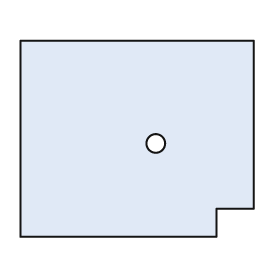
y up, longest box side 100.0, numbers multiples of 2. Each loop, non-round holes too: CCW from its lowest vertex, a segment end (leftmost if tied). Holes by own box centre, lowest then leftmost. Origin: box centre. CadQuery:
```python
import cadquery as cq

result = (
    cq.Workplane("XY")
    .moveTo(-50.0, -42.0)
    .lineTo(34.0, -42.0)
    .lineTo(34.0, -30.0)
    .lineTo(50.0, -30.0)
    .lineTo(50.0, 42.0)
    .lineTo(-50.0, 42.0)
    .close()
    .moveTo(8.0, -2.0)
    .circle(4.0)
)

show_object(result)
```